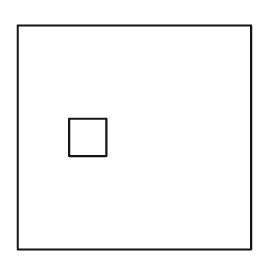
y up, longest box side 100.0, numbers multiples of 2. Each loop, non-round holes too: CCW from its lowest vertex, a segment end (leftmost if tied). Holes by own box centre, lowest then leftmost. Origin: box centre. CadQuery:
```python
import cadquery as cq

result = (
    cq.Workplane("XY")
    .moveTo(-50.0, -48.0)
    .lineTo(50.0, -48.0)
    .lineTo(50.0, 48.0)
    .lineTo(-50.0, 48.0)
    .close()
    .moveTo(-28.0, -8.0)
    .lineTo(-12.0, -8.0)
    .lineTo(-12.0, 8.0)
    .lineTo(-28.0, 8.0)
    .close()
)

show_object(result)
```